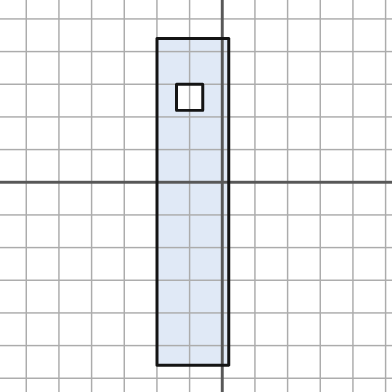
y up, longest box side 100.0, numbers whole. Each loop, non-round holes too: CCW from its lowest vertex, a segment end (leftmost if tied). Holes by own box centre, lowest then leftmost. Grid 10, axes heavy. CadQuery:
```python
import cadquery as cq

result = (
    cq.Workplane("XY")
    .moveTo(-20.0, -56.0)
    .lineTo(2.0, -56.0)
    .lineTo(2.0, 44.0)
    .lineTo(-20.0, 44.0)
    .close()
    .moveTo(-14.0, 22.0)
    .lineTo(-6.0, 22.0)
    .lineTo(-6.0, 30.0)
    .lineTo(-14.0, 30.0)
    .close()
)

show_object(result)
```